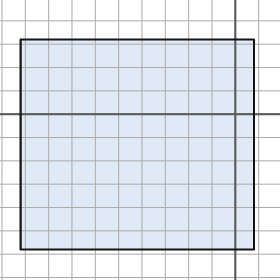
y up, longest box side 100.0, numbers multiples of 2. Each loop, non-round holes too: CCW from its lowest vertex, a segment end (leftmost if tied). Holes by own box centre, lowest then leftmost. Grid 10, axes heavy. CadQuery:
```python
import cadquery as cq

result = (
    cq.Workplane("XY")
    .moveTo(-92.0, -58.0)
    .lineTo(8.0, -58.0)
    .lineTo(8.0, 32.0)
    .lineTo(-92.0, 32.0)
    .close()
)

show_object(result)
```